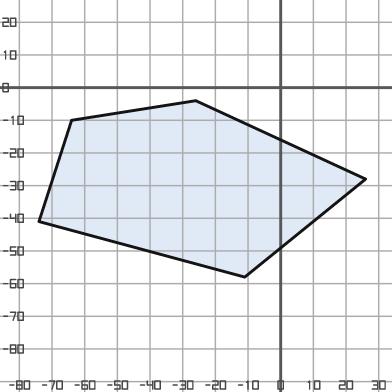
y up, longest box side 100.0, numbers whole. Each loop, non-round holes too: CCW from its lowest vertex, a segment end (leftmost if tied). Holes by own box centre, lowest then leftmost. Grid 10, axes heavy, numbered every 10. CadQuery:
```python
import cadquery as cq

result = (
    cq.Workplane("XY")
    .moveTo(-11.0, -58.0)
    .lineTo(26.0, -28.0)
    .lineTo(-26.0, -4.0)
    .lineTo(-64.0, -10.0)
    .lineTo(-74.0, -41.0)
    .close()
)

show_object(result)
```